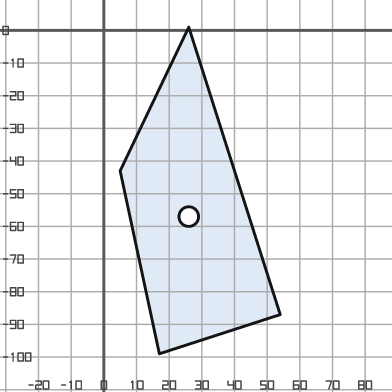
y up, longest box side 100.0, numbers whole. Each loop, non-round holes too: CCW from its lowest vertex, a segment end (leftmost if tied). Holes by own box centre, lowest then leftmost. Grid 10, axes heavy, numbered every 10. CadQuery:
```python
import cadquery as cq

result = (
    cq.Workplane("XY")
    .moveTo(17.0, -99.0)
    .lineTo(54.0, -87.0)
    .lineTo(26.0, 1.0)
    .lineTo(5.0, -43.0)
    .close()
    .moveTo(26.0, -57.0)
    .circle(3.0)
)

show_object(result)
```